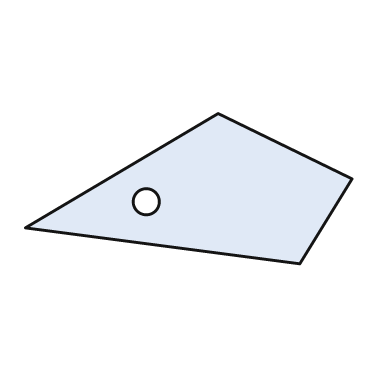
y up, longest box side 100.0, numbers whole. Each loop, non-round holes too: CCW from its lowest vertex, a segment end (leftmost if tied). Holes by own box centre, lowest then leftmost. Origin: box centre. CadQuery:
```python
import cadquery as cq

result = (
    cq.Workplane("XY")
    .moveTo(34.0, -23.0)
    .lineTo(50.0, 3.0)
    .lineTo(9.0, 23.0)
    .lineTo(-50.0, -12.0)
    .close()
    .moveTo(-13.0, -4.0)
    .circle(4.0)
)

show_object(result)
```